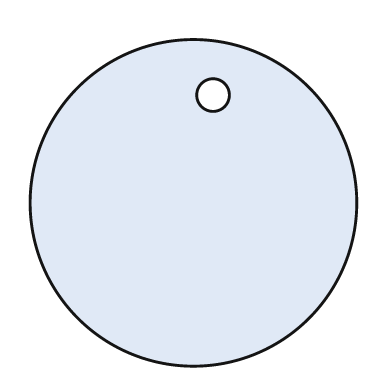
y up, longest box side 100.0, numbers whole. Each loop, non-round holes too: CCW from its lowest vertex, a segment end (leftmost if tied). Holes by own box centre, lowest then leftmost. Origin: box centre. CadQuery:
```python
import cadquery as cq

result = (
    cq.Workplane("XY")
    .moveTo(0.0, 0.0)
    .circle(50.0)
    .moveTo(6.0, 33.0)
    .circle(5.0)
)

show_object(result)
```